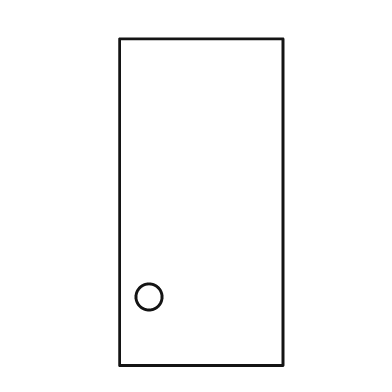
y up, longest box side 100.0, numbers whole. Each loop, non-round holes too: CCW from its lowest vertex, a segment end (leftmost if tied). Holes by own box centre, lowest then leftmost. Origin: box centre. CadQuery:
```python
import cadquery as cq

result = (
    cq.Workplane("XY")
    .moveTo(-25.0, -50.0)
    .lineTo(25.0, -50.0)
    .lineTo(25.0, 50.0)
    .lineTo(-25.0, 50.0)
    .close()
    .moveTo(-16.0, -29.0)
    .circle(4.0)
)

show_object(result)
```